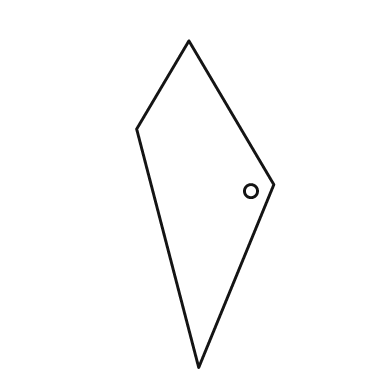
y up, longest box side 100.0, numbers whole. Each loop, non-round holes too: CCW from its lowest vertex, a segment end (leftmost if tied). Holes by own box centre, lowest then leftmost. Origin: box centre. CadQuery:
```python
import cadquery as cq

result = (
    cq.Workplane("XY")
    .moveTo(-2.0, -50.0)
    .lineTo(21.0, 6.0)
    .lineTo(-5.0, 50.0)
    .lineTo(-21.0, 23.0)
    .close()
    .moveTo(14.0, 4.0)
    .circle(2.0)
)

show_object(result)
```